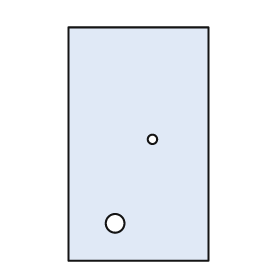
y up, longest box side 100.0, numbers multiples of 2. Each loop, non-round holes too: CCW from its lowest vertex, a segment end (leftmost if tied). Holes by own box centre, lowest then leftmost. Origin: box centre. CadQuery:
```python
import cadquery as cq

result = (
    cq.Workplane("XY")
    .moveTo(-30.0, -50.0)
    .lineTo(30.0, -50.0)
    .lineTo(30.0, 50.0)
    .lineTo(-30.0, 50.0)
    .close()
    .moveTo(-10.0, -34.0)
    .circle(4.0)
    .moveTo(6.0, 2.0)
    .circle(2.0)
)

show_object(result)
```